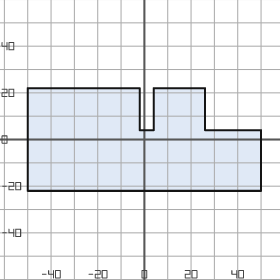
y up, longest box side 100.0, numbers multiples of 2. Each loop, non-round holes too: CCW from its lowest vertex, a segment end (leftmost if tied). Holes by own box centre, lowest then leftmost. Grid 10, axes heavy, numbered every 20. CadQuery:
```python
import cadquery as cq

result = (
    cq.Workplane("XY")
    .moveTo(-50.0, -22.0)
    .lineTo(50.0, -22.0)
    .lineTo(50.0, 4.0)
    .lineTo(26.0, 4.0)
    .lineTo(26.0, 22.0)
    .lineTo(4.0, 22.0)
    .lineTo(4.0, 4.0)
    .lineTo(-2.0, 4.0)
    .lineTo(-2.0, 22.0)
    .lineTo(-50.0, 22.0)
    .close()
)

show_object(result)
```